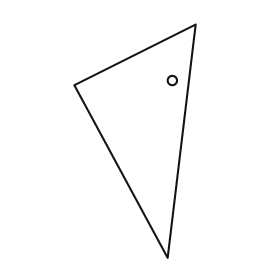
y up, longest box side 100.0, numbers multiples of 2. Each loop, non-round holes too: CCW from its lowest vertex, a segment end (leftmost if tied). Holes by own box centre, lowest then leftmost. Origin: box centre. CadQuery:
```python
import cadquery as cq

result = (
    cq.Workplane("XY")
    .moveTo(14.0, -50.0)
    .lineTo(26.0, 50.0)
    .lineTo(-26.0, 24.0)
    .close()
    .moveTo(16.0, 26.0)
    .circle(2.0)
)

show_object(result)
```